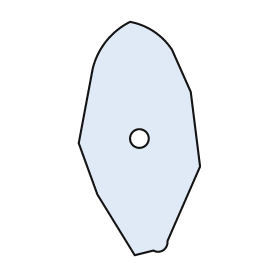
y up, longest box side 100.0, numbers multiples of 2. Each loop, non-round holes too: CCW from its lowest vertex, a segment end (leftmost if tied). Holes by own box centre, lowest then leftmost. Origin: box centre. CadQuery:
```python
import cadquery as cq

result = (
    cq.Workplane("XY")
    .moveTo(-2.0, -50.0)
    .lineTo(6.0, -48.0)
    .threePointArc((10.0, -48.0), (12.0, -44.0))
    .lineTo(26.0, -12.0)
    .lineTo(22.0, 20.0)
    .lineTo(14.0, 38.0)
    .threePointArc((6.0, 46.0), (-4.0, 50.0))
    .threePointArc((-14.0, 42.0), (-20.0, 30.0))
    .lineTo(-26.0, -2.0)
    .lineTo(-18.0, -24.0)
    .close()
    .moveTo(0.0, 0.0)
    .circle(4.0)
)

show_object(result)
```